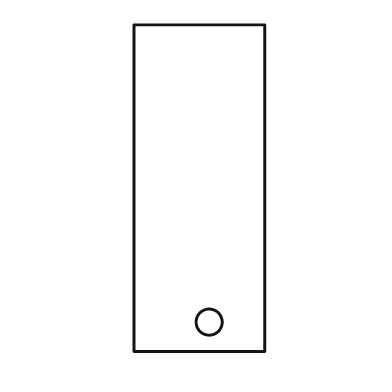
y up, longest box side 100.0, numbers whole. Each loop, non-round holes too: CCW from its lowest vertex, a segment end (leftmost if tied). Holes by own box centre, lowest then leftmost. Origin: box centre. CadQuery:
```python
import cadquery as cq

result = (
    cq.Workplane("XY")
    .moveTo(-20.0, -50.0)
    .lineTo(20.0, -50.0)
    .lineTo(20.0, 50.0)
    .lineTo(-20.0, 50.0)
    .close()
    .moveTo(3.0, -41.0)
    .circle(4.0)
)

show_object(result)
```